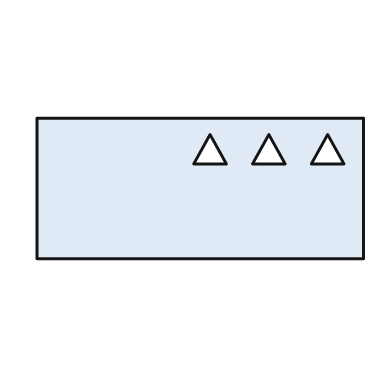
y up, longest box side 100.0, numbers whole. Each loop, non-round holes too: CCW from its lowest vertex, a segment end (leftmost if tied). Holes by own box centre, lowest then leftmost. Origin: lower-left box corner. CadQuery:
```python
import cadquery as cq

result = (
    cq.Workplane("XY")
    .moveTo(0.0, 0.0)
    .lineTo(100.0, 0.0)
    .lineTo(100.0, 43.0)
    .lineTo(0.0, 43.0)
    .close()
    .moveTo(48.0, 29.0)
    .lineTo(58.0, 29.0)
    .lineTo(53.0, 38.0)
    .close()
    .moveTo(66.0, 29.0)
    .lineTo(76.0, 29.0)
    .lineTo(71.0, 38.0)
    .close()
    .moveTo(84.0, 29.0)
    .lineTo(94.0, 29.0)
    .lineTo(89.0, 38.0)
    .close()
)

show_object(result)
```